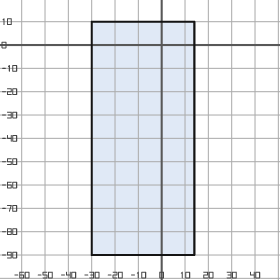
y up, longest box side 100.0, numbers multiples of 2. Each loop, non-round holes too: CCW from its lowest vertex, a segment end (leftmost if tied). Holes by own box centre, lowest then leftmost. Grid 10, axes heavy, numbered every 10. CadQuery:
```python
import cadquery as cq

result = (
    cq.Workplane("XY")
    .moveTo(-30.0, -90.0)
    .lineTo(14.0, -90.0)
    .lineTo(14.0, 10.0)
    .lineTo(-30.0, 10.0)
    .close()
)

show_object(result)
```